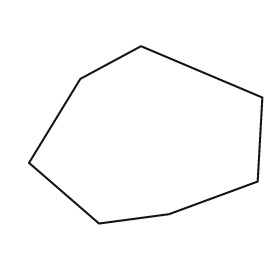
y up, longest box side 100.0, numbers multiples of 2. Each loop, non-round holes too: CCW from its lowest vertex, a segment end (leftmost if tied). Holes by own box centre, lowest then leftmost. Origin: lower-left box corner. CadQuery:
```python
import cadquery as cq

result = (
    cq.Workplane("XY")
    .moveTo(30.0, 0.0)
    .lineTo(60.0, 4.0)
    .lineTo(98.0, 18.0)
    .lineTo(100.0, 54.0)
    .lineTo(48.0, 76.0)
    .lineTo(22.0, 62.0)
    .lineTo(0.0, 26.0)
    .close()
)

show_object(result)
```